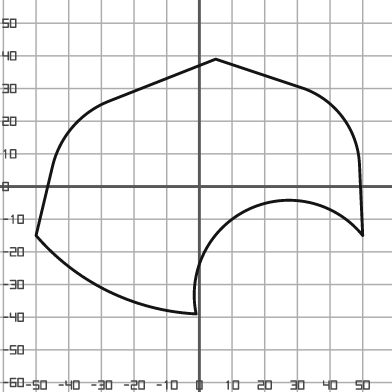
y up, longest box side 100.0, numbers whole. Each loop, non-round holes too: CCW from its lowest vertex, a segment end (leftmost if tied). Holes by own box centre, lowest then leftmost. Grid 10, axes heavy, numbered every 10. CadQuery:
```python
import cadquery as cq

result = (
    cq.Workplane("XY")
    .moveTo(-1.0, -39.0)
    .threePointArc((15.0, -7.0), (50.0, -15.0))
    .lineTo(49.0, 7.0)
    .threePointArc((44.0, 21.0), (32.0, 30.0))
    .lineTo(5.0, 39.0)
    .lineTo(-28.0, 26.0)
    .threePointArc((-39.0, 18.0), (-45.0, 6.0))
    .lineTo(-50.0, -15.0)
    .threePointArc((-28.0, -32.0), (-1.0, -39.0))
    .close()
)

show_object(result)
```